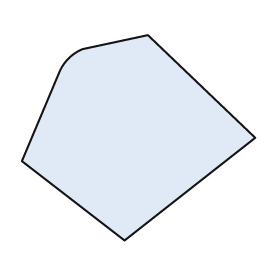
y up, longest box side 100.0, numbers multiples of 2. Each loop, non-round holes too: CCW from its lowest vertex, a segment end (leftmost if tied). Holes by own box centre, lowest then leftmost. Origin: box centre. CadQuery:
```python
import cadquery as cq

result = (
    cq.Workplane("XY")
    .moveTo(-6.0, -44.0)
    .lineTo(50.0, 0.0)
    .lineTo(4.0, 44.0)
    .lineTo(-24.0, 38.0)
    .threePointArc((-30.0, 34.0), (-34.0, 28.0))
    .lineTo(-50.0, -10.0)
    .close()
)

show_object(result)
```